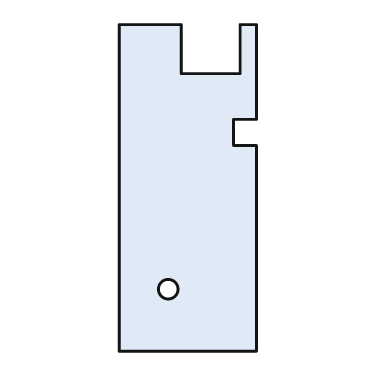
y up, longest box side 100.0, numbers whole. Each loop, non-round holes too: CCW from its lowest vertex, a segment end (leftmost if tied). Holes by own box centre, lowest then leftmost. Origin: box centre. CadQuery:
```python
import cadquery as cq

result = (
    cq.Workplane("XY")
    .moveTo(-21.0, -50.0)
    .lineTo(21.0, -50.0)
    .lineTo(21.0, 13.0)
    .lineTo(14.0, 13.0)
    .lineTo(14.0, 21.0)
    .lineTo(21.0, 21.0)
    .lineTo(21.0, 50.0)
    .lineTo(16.0, 50.0)
    .lineTo(16.0, 35.0)
    .lineTo(-2.0, 35.0)
    .lineTo(-2.0, 50.0)
    .lineTo(-21.0, 50.0)
    .close()
    .moveTo(-6.0, -31.0)
    .circle(3.0)
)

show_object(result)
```